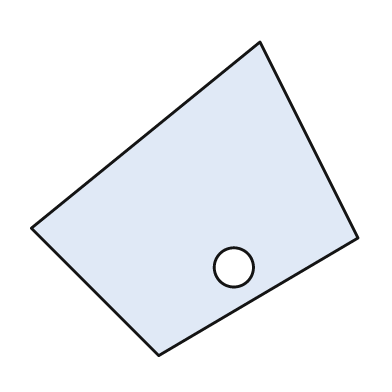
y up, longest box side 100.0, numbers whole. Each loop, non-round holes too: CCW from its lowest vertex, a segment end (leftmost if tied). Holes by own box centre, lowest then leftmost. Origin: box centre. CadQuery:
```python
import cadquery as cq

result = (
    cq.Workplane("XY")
    .moveTo(-11.0, -48.0)
    .lineTo(50.0, -12.0)
    .lineTo(20.0, 48.0)
    .lineTo(-50.0, -9.0)
    .close()
    .moveTo(12.0, -21.0)
    .circle(6.0)
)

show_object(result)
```